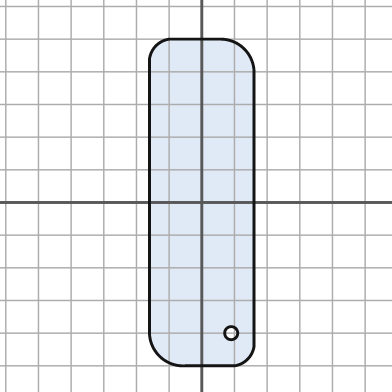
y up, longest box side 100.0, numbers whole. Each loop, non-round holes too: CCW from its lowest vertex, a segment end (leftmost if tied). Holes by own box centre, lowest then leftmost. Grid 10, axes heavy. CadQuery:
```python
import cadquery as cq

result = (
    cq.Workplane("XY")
    .moveTo(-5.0, -50.0)
    .lineTo(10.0, -50.0)
    .threePointArc((14.0, -48.0), (16.0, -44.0))
    .lineTo(16.0, 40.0)
    .threePointArc((13.0, 47.0), (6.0, 50.0))
    .lineTo(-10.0, 50.0)
    .threePointArc((-14.0, 48.0), (-16.0, 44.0))
    .lineTo(-16.0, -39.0)
    .threePointArc((-13.0, -47.0), (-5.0, -50.0))
    .close()
    .moveTo(9.0, -40.0)
    .circle(2.0)
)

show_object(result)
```